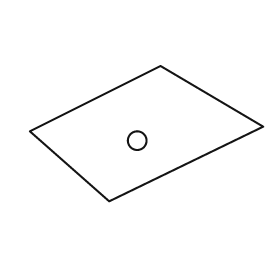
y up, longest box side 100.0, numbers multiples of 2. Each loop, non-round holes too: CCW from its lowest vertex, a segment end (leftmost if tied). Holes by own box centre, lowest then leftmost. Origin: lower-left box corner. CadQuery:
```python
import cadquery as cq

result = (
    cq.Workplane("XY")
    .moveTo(34.0, 0.0)
    .lineTo(100.0, 32.0)
    .lineTo(56.0, 58.0)
    .lineTo(0.0, 30.0)
    .close()
    .moveTo(46.0, 26.0)
    .circle(4.0)
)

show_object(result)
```